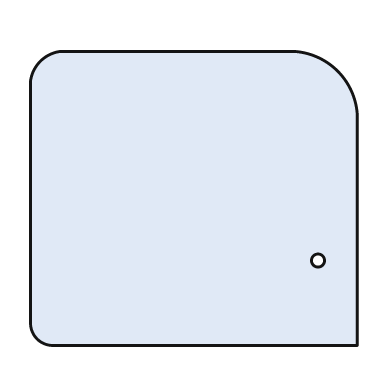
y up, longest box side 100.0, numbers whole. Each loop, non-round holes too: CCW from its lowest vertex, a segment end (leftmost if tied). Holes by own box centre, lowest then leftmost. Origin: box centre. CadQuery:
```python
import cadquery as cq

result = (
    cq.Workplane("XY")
    .moveTo(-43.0, -45.0)
    .lineTo(50.0, -45.0)
    .lineTo(50.0, 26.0)
    .threePointArc((44.0, 39.0), (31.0, 45.0))
    .lineTo(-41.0, 45.0)
    .threePointArc((-47.0, 42.0), (-50.0, 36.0))
    .lineTo(-50.0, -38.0)
    .threePointArc((-48.0, -43.0), (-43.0, -45.0))
    .close()
    .moveTo(38.0, -19.0)
    .circle(2.0)
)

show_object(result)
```